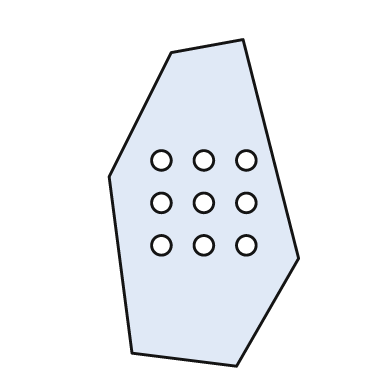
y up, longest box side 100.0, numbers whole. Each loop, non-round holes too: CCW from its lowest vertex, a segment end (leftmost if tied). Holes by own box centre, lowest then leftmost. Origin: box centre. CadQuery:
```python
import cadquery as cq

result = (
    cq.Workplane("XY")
    .moveTo(10.0, -50.0)
    .lineTo(29.0, -17.0)
    .lineTo(12.0, 50.0)
    .lineTo(-10.0, 46.0)
    .lineTo(-29.0, 8.0)
    .lineTo(-22.0, -46.0)
    .close()
    .moveTo(-13.0, -13.0)
    .circle(3.0)
    .moveTo(0.0, -13.0)
    .circle(3.0)
    .moveTo(13.0, -13.0)
    .circle(3.0)
    .moveTo(-13.0, 0.0)
    .circle(3.0)
    .moveTo(0.0, 0.0)
    .circle(3.0)
    .moveTo(13.0, 0.0)
    .circle(3.0)
    .moveTo(-13.0, 13.0)
    .circle(3.0)
    .moveTo(0.0, 13.0)
    .circle(3.0)
    .moveTo(13.0, 13.0)
    .circle(3.0)
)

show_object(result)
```